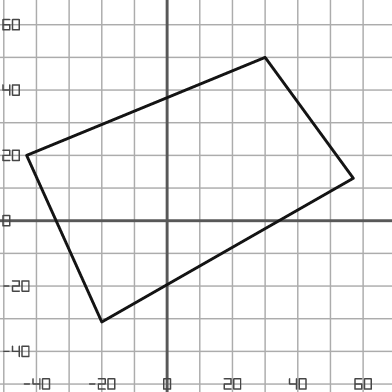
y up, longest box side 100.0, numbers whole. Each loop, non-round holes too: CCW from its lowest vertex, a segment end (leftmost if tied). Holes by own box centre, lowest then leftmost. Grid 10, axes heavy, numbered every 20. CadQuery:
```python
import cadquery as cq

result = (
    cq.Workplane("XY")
    .moveTo(-20.0, -31.0)
    .lineTo(57.0, 13.0)
    .lineTo(30.0, 50.0)
    .lineTo(-43.0, 20.0)
    .close()
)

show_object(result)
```